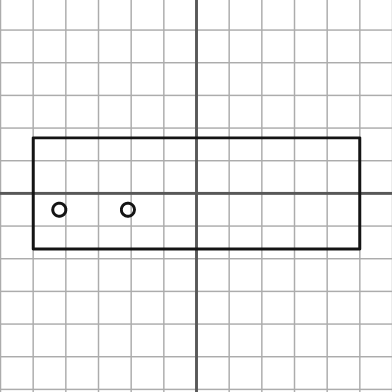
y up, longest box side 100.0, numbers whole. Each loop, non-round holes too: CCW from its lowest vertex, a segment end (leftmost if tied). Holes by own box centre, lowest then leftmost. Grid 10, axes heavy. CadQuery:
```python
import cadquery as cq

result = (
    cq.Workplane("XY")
    .moveTo(-50.0, -17.0)
    .lineTo(50.0, -17.0)
    .lineTo(50.0, 17.0)
    .lineTo(-50.0, 17.0)
    .close()
    .moveTo(-42.0, -5.0)
    .circle(2.0)
    .moveTo(-21.0, -5.0)
    .circle(2.0)
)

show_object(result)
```